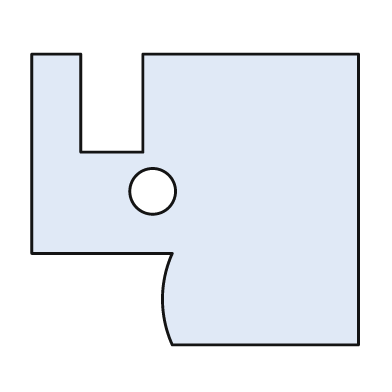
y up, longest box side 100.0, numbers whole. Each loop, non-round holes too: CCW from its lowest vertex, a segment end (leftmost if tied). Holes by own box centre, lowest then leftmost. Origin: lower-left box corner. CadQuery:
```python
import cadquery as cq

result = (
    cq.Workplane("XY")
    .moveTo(43.0, 0.0)
    .lineTo(100.0, 0.0)
    .lineTo(100.0, 89.0)
    .lineTo(34.0, 89.0)
    .lineTo(34.0, 59.0)
    .lineTo(15.0, 59.0)
    .lineTo(15.0, 89.0)
    .lineTo(0.0, 89.0)
    .lineTo(0.0, 28.0)
    .lineTo(43.0, 28.0)
    .threePointArc((40.0, 14.0), (43.0, 0.0))
    .close()
    .moveTo(37.0, 47.0)
    .circle(7.0)
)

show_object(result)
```